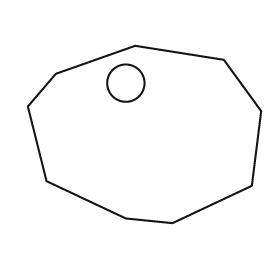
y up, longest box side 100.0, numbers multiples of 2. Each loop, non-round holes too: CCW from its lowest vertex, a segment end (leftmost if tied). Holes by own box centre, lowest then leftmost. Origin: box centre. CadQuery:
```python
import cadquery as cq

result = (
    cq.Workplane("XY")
    .moveTo(12.0, -38.0)
    .lineTo(46.0, -22.0)
    .lineTo(50.0, 10.0)
    .lineTo(34.0, 32.0)
    .lineTo(-4.0, 38.0)
    .lineTo(-38.0, 26.0)
    .lineTo(-50.0, 12.0)
    .lineTo(-42.0, -20.0)
    .lineTo(-8.0, -36.0)
    .close()
    .moveTo(-8.0, 22.0)
    .circle(8.0)
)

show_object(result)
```